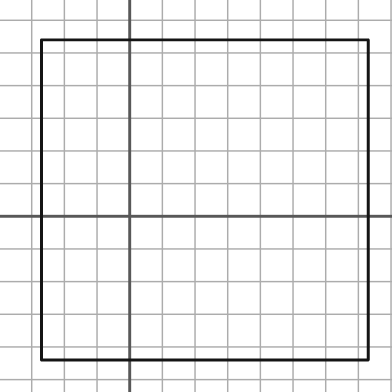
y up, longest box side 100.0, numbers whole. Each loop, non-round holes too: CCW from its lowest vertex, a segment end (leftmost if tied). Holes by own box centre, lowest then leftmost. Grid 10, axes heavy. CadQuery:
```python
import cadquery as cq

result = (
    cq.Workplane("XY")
    .moveTo(-27.0, -44.0)
    .lineTo(73.0, -44.0)
    .lineTo(73.0, 54.0)
    .lineTo(-27.0, 54.0)
    .close()
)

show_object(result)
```